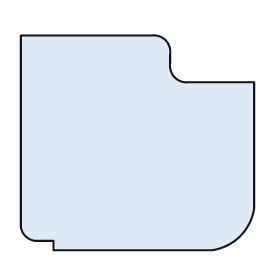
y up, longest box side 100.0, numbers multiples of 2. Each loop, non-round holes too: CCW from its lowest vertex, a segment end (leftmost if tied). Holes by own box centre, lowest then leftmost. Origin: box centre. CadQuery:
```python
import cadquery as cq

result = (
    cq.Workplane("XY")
    .moveTo(-36.0, -46.0)
    .lineTo(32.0, -46.0)
    .threePointArc((44.0, -40.0), (50.0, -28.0))
    .lineTo(50.0, 26.0)
    .lineTo(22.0, 26.0)
    .threePointArc((16.0, 28.0), (14.0, 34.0))
    .lineTo(14.0, 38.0)
    .threePointArc((12.0, 44.0), (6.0, 46.0))
    .lineTo(-50.0, 46.0)
    .lineTo(-50.0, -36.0)
    .threePointArc((-48.0, -40.0), (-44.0, -42.0))
    .lineTo(-36.0, -42.0)
    .close()
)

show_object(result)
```